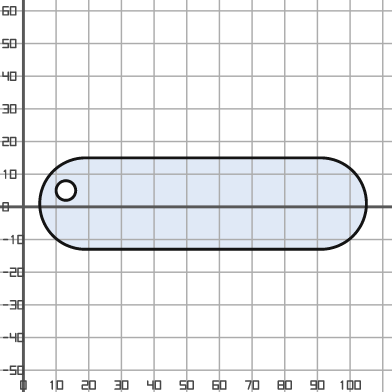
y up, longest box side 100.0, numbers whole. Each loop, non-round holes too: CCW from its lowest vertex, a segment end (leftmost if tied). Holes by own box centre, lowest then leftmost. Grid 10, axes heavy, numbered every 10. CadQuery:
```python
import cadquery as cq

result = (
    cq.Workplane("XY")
    .moveTo(19.0, -13.0)
    .lineTo(91.0, -13.0)
    .threePointArc((105.0, 1.0), (91.0, 15.0))
    .lineTo(19.0, 15.0)
    .threePointArc((5.0, 1.0), (19.0, -13.0))
    .close()
    .moveTo(13.0, 5.0)
    .circle(3.0)
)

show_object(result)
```